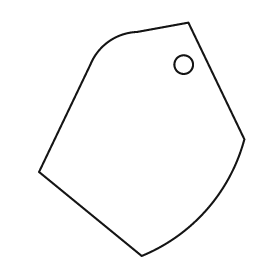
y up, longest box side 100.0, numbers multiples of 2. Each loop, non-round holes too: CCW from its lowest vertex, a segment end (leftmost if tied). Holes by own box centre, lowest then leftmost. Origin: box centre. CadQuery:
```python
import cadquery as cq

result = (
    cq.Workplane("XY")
    .moveTo(0.0, -50.0)
    .threePointArc((28.0, -30.0), (44.0, 0.0))
    .lineTo(20.0, 50.0)
    .lineTo(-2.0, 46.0)
    .threePointArc((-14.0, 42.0), (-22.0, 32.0))
    .lineTo(-44.0, -14.0)
    .close()
    .moveTo(18.0, 32.0)
    .circle(4.0)
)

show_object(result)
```